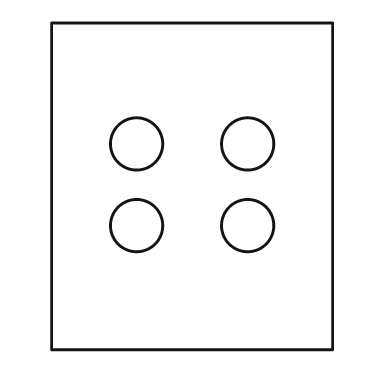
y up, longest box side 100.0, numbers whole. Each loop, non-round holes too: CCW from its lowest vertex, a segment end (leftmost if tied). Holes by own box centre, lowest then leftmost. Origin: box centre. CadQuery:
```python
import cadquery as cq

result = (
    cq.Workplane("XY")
    .moveTo(-43.0, -50.0)
    .lineTo(43.0, -50.0)
    .lineTo(43.0, 50.0)
    .lineTo(-43.0, 50.0)
    .close()
    .moveTo(-17.0, -12.0)
    .circle(8.0)
    .moveTo(17.0, -12.0)
    .circle(8.0)
    .moveTo(-17.0, 13.0)
    .circle(8.0)
    .moveTo(17.0, 13.0)
    .circle(8.0)
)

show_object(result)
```